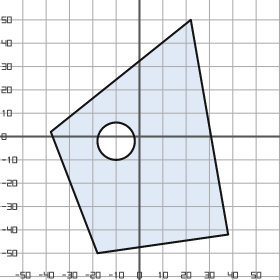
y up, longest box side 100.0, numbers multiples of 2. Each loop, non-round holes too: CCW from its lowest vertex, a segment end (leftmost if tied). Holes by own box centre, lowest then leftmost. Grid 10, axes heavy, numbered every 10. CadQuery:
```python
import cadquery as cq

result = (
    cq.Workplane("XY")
    .moveTo(-18.0, -50.0)
    .lineTo(38.0, -42.0)
    .lineTo(22.0, 50.0)
    .lineTo(-38.0, 2.0)
    .close()
    .moveTo(-10.0, -2.0)
    .circle(8.0)
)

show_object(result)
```